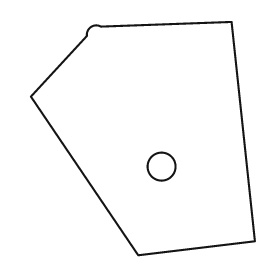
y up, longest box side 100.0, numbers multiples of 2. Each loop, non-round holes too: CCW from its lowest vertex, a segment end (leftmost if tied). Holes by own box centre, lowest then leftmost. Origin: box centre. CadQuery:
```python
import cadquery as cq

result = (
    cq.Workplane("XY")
    .moveTo(-2.0, -50.0)
    .lineTo(48.0, -44.0)
    .lineTo(38.0, 50.0)
    .lineTo(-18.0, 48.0)
    .threePointArc((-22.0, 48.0), (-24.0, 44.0))
    .lineTo(-48.0, 18.0)
    .close()
    .moveTo(8.0, -12.0)
    .circle(6.0)
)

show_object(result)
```